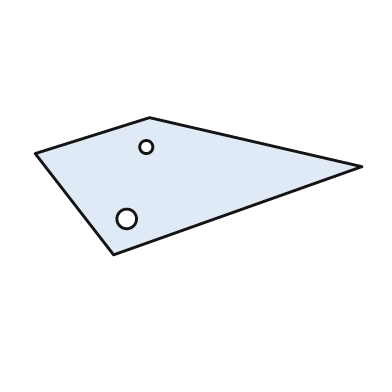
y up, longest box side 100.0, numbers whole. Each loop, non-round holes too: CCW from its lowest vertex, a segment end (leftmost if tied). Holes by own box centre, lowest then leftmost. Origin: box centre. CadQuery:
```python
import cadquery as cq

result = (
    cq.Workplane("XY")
    .moveTo(-26.0, -21.0)
    .lineTo(50.0, 6.0)
    .lineTo(-15.0, 21.0)
    .lineTo(-50.0, 10.0)
    .close()
    .moveTo(-22.0, -10.0)
    .circle(3.0)
    .moveTo(-16.0, 12.0)
    .circle(2.0)
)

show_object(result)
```